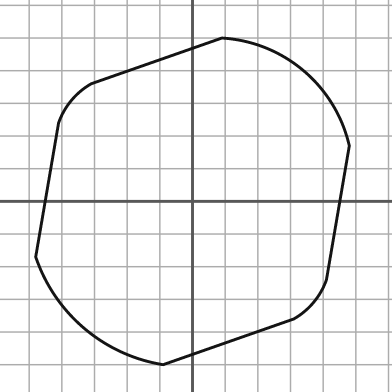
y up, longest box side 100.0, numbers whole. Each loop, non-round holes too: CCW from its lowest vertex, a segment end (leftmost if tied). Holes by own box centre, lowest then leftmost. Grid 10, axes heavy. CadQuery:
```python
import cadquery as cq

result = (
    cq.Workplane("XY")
    .moveTo(-9.0, -50.0)
    .lineTo(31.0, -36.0)
    .threePointArc((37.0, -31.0), (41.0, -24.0))
    .lineTo(48.0, 17.0)
    .threePointArc((34.0, 40.0), (9.0, 50.0))
    .lineTo(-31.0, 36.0)
    .threePointArc((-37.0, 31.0), (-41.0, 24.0))
    .lineTo(-48.0, -17.0)
    .threePointArc((-33.0, -39.0), (-9.0, -50.0))
    .close()
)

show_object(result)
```